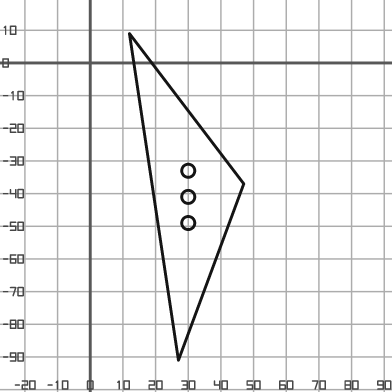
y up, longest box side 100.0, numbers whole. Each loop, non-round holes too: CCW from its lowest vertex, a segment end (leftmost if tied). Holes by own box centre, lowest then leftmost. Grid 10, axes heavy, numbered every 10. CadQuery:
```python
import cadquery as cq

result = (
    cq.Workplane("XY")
    .moveTo(27.0, -91.0)
    .lineTo(47.0, -37.0)
    .lineTo(12.0, 9.0)
    .close()
    .moveTo(30.0, -49.0)
    .circle(2.0)
    .moveTo(30.0, -41.0)
    .circle(2.0)
    .moveTo(30.0, -33.0)
    .circle(2.0)
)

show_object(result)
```